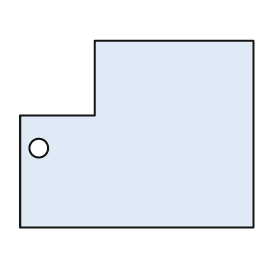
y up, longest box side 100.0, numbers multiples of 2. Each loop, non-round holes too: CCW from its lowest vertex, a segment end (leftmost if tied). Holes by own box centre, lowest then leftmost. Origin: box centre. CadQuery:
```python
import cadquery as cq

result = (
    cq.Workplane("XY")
    .moveTo(-50.0, -40.0)
    .lineTo(50.0, -40.0)
    .lineTo(50.0, 40.0)
    .lineTo(-18.0, 40.0)
    .lineTo(-18.0, 8.0)
    .lineTo(-50.0, 8.0)
    .close()
    .moveTo(-42.0, -6.0)
    .circle(4.0)
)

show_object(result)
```